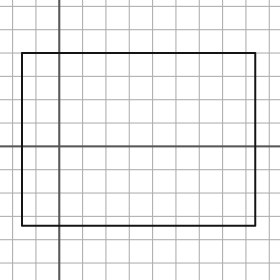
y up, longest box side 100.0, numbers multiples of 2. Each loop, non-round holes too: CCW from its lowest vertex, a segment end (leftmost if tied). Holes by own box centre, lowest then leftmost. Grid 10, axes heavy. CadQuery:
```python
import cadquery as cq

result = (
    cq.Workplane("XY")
    .moveTo(-16.0, -34.0)
    .lineTo(84.0, -34.0)
    .lineTo(84.0, 40.0)
    .lineTo(-16.0, 40.0)
    .close()
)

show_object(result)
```